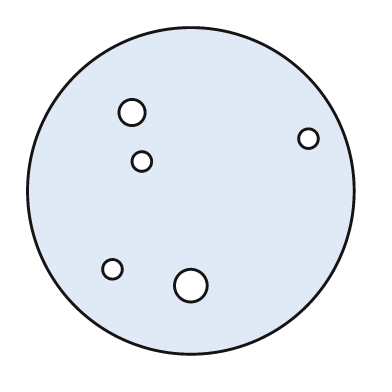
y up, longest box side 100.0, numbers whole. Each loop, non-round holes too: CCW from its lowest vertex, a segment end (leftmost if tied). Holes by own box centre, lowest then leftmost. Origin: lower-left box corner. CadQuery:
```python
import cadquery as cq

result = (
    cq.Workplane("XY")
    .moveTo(50.0, 50.0)
    .circle(50.0)
    .moveTo(50.0, 21.0)
    .circle(5.0)
    .moveTo(26.0, 26.0)
    .circle(3.0)
    .moveTo(35.0, 59.0)
    .circle(3.0)
    .moveTo(86.0, 66.0)
    .circle(3.0)
    .moveTo(32.0, 74.0)
    .circle(4.0)
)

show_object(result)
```